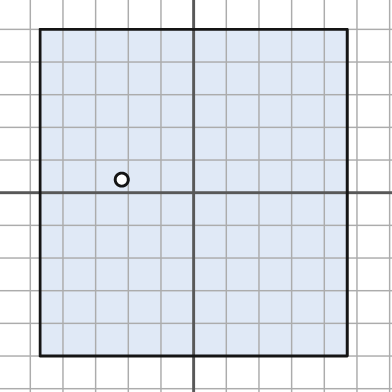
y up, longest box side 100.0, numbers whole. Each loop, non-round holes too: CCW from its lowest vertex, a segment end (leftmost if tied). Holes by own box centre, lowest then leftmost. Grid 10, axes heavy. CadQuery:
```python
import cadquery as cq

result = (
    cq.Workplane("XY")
    .moveTo(-47.0, -50.0)
    .lineTo(47.0, -50.0)
    .lineTo(47.0, 50.0)
    .lineTo(-47.0, 50.0)
    .close()
    .moveTo(-22.0, 4.0)
    .circle(2.0)
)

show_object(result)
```